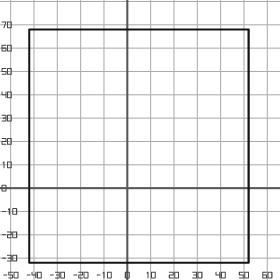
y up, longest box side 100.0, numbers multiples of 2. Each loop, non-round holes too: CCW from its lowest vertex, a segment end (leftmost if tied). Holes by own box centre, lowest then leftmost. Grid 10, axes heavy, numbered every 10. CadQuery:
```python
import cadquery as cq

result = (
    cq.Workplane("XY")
    .moveTo(-42.0, -32.0)
    .lineTo(52.0, -32.0)
    .lineTo(52.0, 68.0)
    .lineTo(-42.0, 68.0)
    .close()
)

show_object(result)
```